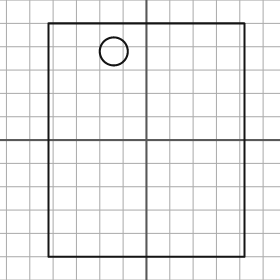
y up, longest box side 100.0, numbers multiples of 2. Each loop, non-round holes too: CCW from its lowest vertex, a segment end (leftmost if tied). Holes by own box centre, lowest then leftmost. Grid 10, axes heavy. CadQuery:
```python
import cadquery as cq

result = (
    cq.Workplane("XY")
    .moveTo(-42.0, -50.0)
    .lineTo(42.0, -50.0)
    .lineTo(42.0, 50.0)
    .lineTo(-42.0, 50.0)
    .close()
    .moveTo(-14.0, 38.0)
    .circle(6.0)
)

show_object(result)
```